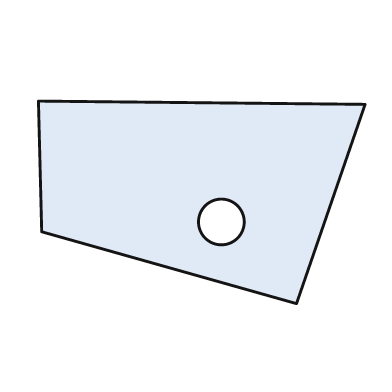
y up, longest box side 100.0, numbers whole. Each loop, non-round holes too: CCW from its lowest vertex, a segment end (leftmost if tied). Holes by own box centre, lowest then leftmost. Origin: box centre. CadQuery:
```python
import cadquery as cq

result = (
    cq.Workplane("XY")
    .moveTo(29.0, -31.0)
    .lineTo(50.0, 30.0)
    .lineTo(-50.0, 31.0)
    .lineTo(-49.0, -9.0)
    .close()
    .moveTo(6.0, -6.0)
    .circle(7.0)
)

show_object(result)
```